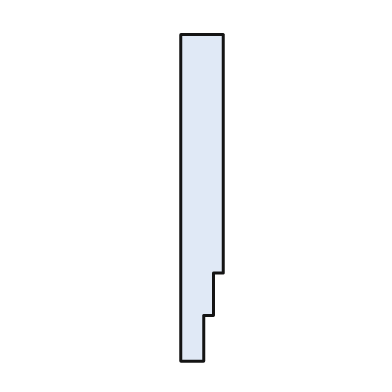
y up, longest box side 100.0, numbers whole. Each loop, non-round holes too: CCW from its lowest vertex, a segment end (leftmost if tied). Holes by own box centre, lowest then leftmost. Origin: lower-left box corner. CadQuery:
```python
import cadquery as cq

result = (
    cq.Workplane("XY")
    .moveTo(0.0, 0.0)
    .lineTo(7.0, 0.0)
    .lineTo(7.0, 14.0)
    .lineTo(10.0, 14.0)
    .lineTo(10.0, 27.0)
    .lineTo(13.0, 27.0)
    .lineTo(13.0, 100.0)
    .lineTo(0.0, 100.0)
    .close()
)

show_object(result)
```